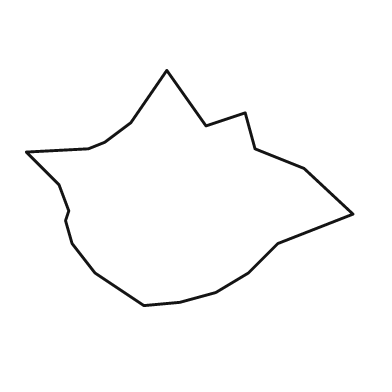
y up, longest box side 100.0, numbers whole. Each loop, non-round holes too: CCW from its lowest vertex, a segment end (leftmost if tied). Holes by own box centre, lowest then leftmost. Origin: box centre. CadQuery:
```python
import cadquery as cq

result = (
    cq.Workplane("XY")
    .moveTo(-14.0, -36.0)
    .lineTo(-3.0, -35.0)
    .lineTo(8.0, -32.0)
    .lineTo(18.0, -26.0)
    .lineTo(27.0, -17.0)
    .lineTo(50.0, -8.0)
    .lineTo(35.0, 6.0)
    .lineTo(20.0, 12.0)
    .lineTo(17.0, 23.0)
    .lineTo(5.0, 19.0)
    .lineTo(-7.0, 36.0)
    .lineTo(-18.0, 20.0)
    .lineTo(-26.0, 14.0)
    .lineTo(-31.0, 12.0)
    .lineTo(-50.0, 11.0)
    .lineTo(-40.0, 1.0)
    .lineTo(-37.0, -7.0)
    .lineTo(-38.0, -10.0)
    .lineTo(-36.0, -17.0)
    .lineTo(-29.0, -26.0)
    .close()
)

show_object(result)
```